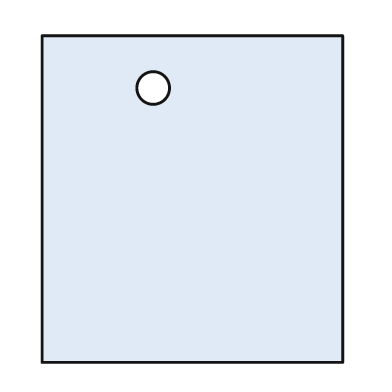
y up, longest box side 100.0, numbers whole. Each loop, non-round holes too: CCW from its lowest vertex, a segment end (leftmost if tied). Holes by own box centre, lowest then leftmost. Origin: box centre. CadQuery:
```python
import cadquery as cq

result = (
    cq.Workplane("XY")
    .moveTo(-46.0, -50.0)
    .lineTo(46.0, -50.0)
    .lineTo(46.0, 50.0)
    .lineTo(-46.0, 50.0)
    .close()
    .moveTo(-12.0, 34.0)
    .circle(5.0)
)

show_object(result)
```